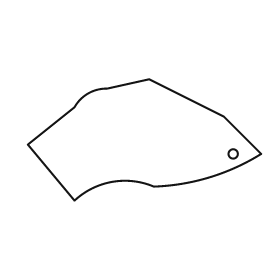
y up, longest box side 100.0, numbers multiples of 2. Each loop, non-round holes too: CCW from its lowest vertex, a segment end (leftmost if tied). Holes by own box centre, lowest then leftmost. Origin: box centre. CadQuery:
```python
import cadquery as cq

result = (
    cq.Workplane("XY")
    .moveTo(-30.0, -26.0)
    .threePointArc((-14.0, -18.0), (4.0, -20.0))
    .threePointArc((28.0, -16.0), (50.0, -6.0))
    .lineTo(34.0, 10.0)
    .lineTo(2.0, 26.0)
    .lineTo(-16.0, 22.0)
    .threePointArc((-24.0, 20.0), (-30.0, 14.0))
    .lineTo(-50.0, -2.0)
    .close()
    .moveTo(38.0, -6.0)
    .circle(2.0)
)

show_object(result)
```